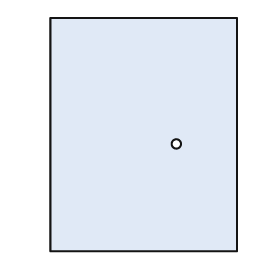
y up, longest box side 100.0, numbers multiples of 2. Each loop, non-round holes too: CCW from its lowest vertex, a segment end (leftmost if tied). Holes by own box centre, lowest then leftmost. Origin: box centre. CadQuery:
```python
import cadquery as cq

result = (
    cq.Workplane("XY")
    .moveTo(-40.0, -50.0)
    .lineTo(40.0, -50.0)
    .lineTo(40.0, 50.0)
    .lineTo(-40.0, 50.0)
    .close()
    .moveTo(14.0, -4.0)
    .circle(2.0)
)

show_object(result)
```